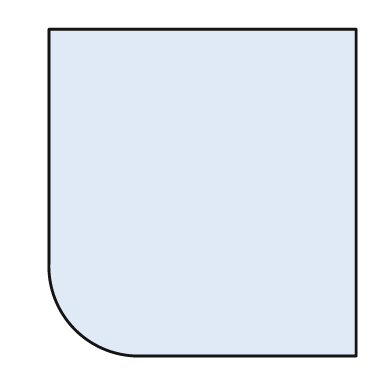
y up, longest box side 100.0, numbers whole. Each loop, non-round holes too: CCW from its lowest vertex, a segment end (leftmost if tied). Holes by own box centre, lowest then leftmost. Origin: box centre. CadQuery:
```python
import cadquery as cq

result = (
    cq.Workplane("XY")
    .moveTo(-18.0, -50.0)
    .lineTo(47.0, -50.0)
    .lineTo(47.0, 50.0)
    .lineTo(-47.0, 50.0)
    .lineTo(-47.0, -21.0)
    .threePointArc((-39.0, -42.0), (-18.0, -50.0))
    .close()
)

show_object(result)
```